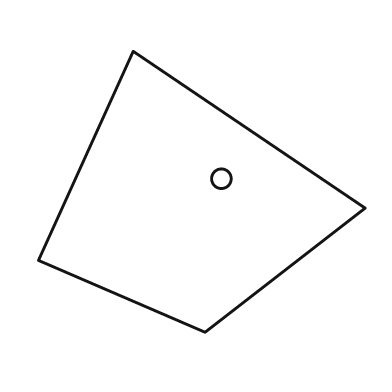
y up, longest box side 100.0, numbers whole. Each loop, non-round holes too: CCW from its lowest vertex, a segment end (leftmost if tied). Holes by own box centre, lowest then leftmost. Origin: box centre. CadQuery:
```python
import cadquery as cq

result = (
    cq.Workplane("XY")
    .moveTo(1.0, -43.0)
    .lineTo(50.0, -5.0)
    .lineTo(-21.0, 43.0)
    .lineTo(-50.0, -21.0)
    .close()
    .moveTo(6.0, 4.0)
    .circle(3.0)
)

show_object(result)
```